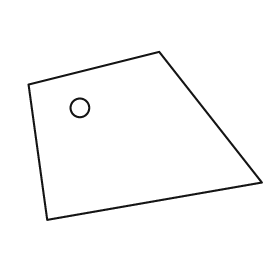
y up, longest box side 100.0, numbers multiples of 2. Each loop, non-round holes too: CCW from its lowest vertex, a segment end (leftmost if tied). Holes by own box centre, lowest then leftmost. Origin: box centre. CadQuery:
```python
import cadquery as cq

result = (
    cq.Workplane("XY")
    .moveTo(-42.0, -36.0)
    .lineTo(50.0, -20.0)
    .lineTo(6.0, 36.0)
    .lineTo(-50.0, 22.0)
    .close()
    .moveTo(-28.0, 12.0)
    .circle(4.0)
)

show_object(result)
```